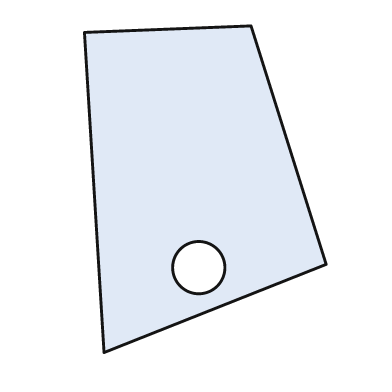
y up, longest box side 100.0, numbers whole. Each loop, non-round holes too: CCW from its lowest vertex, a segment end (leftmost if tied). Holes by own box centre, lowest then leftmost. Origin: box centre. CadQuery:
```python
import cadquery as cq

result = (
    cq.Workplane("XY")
    .moveTo(-31.0, -50.0)
    .lineTo(37.0, -23.0)
    .lineTo(14.0, 50.0)
    .lineTo(-37.0, 48.0)
    .close()
    .moveTo(-2.0, -24.0)
    .circle(8.0)
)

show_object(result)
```